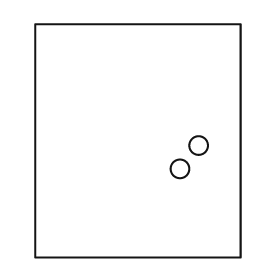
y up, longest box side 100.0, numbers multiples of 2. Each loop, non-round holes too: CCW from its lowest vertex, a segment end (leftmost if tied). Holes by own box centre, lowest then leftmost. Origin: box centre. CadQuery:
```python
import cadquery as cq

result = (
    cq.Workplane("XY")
    .moveTo(-44.0, -50.0)
    .lineTo(44.0, -50.0)
    .lineTo(44.0, 50.0)
    .lineTo(-44.0, 50.0)
    .close()
    .moveTo(18.0, -12.0)
    .circle(4.0)
    .moveTo(26.0, -2.0)
    .circle(4.0)
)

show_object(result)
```